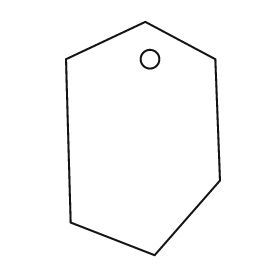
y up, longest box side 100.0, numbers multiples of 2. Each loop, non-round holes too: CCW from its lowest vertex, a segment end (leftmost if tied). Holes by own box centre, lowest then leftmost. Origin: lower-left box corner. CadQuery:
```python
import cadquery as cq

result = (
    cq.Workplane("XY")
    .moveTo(38.0, 0.0)
    .lineTo(66.0, 32.0)
    .lineTo(64.0, 84.0)
    .lineTo(34.0, 100.0)
    .lineTo(0.0, 84.0)
    .lineTo(2.0, 14.0)
    .close()
    .moveTo(36.0, 84.0)
    .circle(4.0)
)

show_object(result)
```